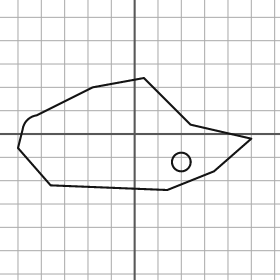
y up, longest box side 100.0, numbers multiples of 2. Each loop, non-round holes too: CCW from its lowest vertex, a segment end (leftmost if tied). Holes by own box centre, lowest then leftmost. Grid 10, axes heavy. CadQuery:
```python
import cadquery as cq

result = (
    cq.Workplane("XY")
    .moveTo(14.0, -24.0)
    .lineTo(34.0, -16.0)
    .lineTo(50.0, -2.0)
    .lineTo(24.0, 4.0)
    .lineTo(4.0, 24.0)
    .lineTo(-18.0, 20.0)
    .lineTo(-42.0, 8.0)
    .threePointArc((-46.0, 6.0), (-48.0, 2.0))
    .lineTo(-50.0, -6.0)
    .lineTo(-36.0, -22.0)
    .close()
    .moveTo(20.0, -12.0)
    .circle(4.0)
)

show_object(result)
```